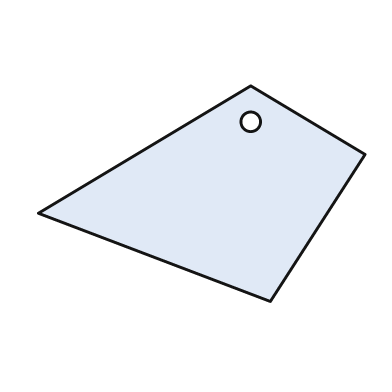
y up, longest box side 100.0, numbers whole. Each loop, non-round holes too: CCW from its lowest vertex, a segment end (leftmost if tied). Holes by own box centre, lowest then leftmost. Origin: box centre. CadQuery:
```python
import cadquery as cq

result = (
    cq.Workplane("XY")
    .moveTo(21.0, -33.0)
    .lineTo(50.0, 12.0)
    .lineTo(15.0, 33.0)
    .lineTo(-50.0, -6.0)
    .close()
    .moveTo(15.0, 22.0)
    .circle(3.0)
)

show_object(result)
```